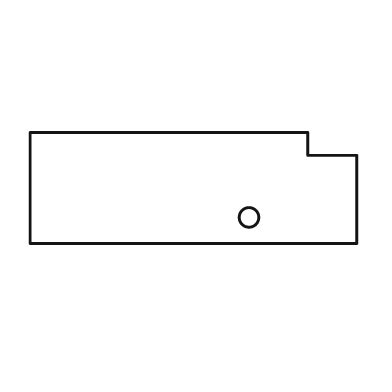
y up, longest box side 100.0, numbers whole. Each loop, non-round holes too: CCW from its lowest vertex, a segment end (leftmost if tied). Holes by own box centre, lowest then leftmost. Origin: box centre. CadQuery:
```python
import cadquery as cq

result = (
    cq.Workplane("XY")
    .moveTo(-50.0, -17.0)
    .lineTo(50.0, -17.0)
    .lineTo(50.0, 10.0)
    .lineTo(35.0, 10.0)
    .lineTo(35.0, 17.0)
    .lineTo(-50.0, 17.0)
    .close()
    .moveTo(17.0, -9.0)
    .circle(3.0)
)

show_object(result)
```